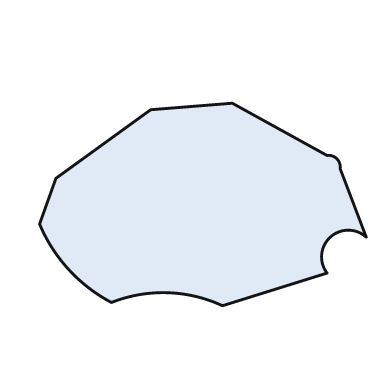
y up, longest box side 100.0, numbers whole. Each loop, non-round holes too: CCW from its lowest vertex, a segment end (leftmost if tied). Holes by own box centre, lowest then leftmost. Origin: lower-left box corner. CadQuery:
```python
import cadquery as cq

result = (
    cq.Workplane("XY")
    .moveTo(56.0, 0.0)
    .lineTo(88.0, 10.0)
    .threePointArc((89.0, 21.0), (100.0, 21.0))
    .lineTo(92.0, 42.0)
    .threePointArc((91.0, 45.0), (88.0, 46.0))
    .lineTo(59.0, 62.0)
    .lineTo(34.0, 60.0)
    .lineTo(5.0, 39.0)
    .lineTo(0.0, 25.0)
    .threePointArc((9.0, 11.0), (22.0, 1.0))
    .threePointArc((39.0, 4.0), (56.0, 0.0))
    .close()
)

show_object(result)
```